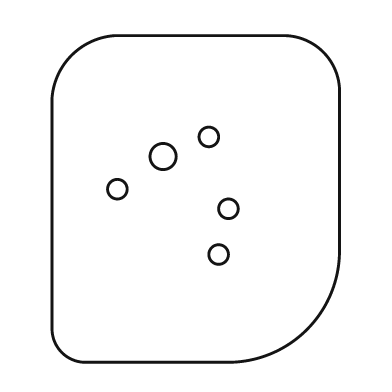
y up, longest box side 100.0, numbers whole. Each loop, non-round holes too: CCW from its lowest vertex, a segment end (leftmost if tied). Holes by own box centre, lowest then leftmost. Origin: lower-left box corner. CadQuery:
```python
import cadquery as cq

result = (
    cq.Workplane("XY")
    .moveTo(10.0, 0.0)
    .lineTo(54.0, 0.0)
    .threePointArc((78.0, 10.0), (88.0, 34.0))
    .lineTo(88.0, 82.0)
    .threePointArc((83.0, 95.0), (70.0, 100.0))
    .lineTo(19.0, 100.0)
    .threePointArc((6.0, 94.0), (0.0, 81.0))
    .lineTo(0.0, 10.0)
    .threePointArc((3.0, 3.0), (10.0, 0.0))
    .close()
    .moveTo(51.0, 33.0)
    .circle(3.0)
    .moveTo(54.0, 47.0)
    .circle(3.0)
    .moveTo(20.0, 53.0)
    .circle(3.0)
    .moveTo(34.0, 63.0)
    .circle(4.0)
    .moveTo(48.0, 69.0)
    .circle(3.0)
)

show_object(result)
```